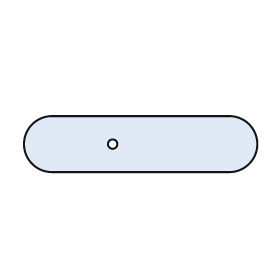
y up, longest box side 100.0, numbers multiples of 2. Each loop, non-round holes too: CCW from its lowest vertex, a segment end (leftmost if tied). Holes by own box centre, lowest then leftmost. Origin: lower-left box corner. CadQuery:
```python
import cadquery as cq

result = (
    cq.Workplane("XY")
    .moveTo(12.0, 0.0)
    .lineTo(88.0, 0.0)
    .threePointArc((100.0, 12.0), (88.0, 24.0))
    .lineTo(12.0, 24.0)
    .threePointArc((0.0, 12.0), (12.0, 0.0))
    .close()
    .moveTo(38.0, 12.0)
    .circle(2.0)
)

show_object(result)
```